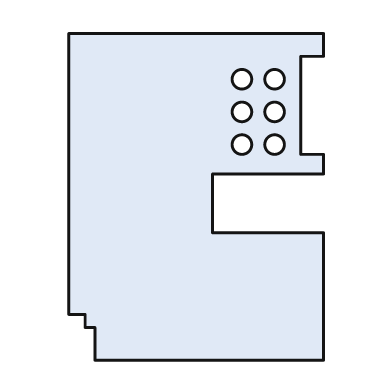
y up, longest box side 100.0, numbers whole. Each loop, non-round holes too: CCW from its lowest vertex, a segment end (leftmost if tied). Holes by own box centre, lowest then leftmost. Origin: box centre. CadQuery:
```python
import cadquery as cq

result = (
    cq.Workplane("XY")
    .moveTo(-31.0, -50.0)
    .lineTo(39.0, -50.0)
    .lineTo(39.0, -11.0)
    .lineTo(5.0, -11.0)
    .lineTo(5.0, 7.0)
    .lineTo(39.0, 7.0)
    .lineTo(39.0, 13.0)
    .lineTo(32.0, 13.0)
    .lineTo(32.0, 43.0)
    .lineTo(39.0, 43.0)
    .lineTo(39.0, 50.0)
    .lineTo(-39.0, 50.0)
    .lineTo(-39.0, -36.0)
    .lineTo(-34.0, -36.0)
    .lineTo(-34.0, -40.0)
    .lineTo(-31.0, -40.0)
    .close()
    .moveTo(14.0, 16.0)
    .circle(3.0)
    .moveTo(24.0, 16.0)
    .circle(3.0)
    .moveTo(14.0, 26.0)
    .circle(3.0)
    .moveTo(24.0, 26.0)
    .circle(3.0)
    .moveTo(14.0, 36.0)
    .circle(3.0)
    .moveTo(24.0, 36.0)
    .circle(3.0)
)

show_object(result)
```